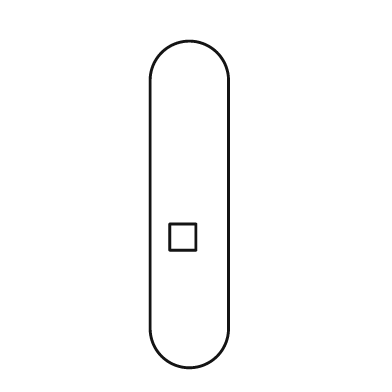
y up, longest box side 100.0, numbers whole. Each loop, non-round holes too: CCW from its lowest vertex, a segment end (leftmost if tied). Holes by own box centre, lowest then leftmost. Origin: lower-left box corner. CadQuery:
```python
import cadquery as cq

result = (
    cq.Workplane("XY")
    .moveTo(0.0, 12.0)
    .threePointArc((12.0, 0.0), (24.0, 12.0))
    .lineTo(24.0, 88.0)
    .threePointArc((12.0, 100.0), (0.0, 88.0))
    .close()
    .moveTo(6.0, 36.0)
    .lineTo(14.0, 36.0)
    .lineTo(14.0, 44.0)
    .lineTo(6.0, 44.0)
    .close()
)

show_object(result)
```